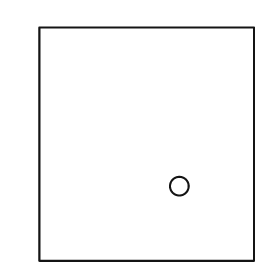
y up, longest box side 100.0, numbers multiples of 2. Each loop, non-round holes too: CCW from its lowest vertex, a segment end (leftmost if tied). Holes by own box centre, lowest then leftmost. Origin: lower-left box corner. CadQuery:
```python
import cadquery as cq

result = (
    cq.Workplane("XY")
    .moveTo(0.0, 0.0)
    .lineTo(92.0, 0.0)
    .lineTo(92.0, 100.0)
    .lineTo(0.0, 100.0)
    .close()
    .moveTo(60.0, 32.0)
    .circle(4.0)
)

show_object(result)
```